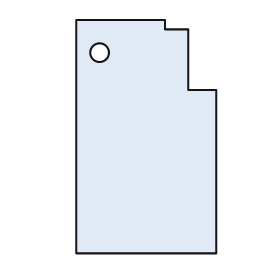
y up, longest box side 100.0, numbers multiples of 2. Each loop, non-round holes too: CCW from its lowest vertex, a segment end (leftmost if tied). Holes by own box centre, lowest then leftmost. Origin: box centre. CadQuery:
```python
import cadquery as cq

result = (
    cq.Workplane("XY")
    .moveTo(-30.0, -50.0)
    .lineTo(30.0, -50.0)
    .lineTo(30.0, 20.0)
    .lineTo(18.0, 20.0)
    .lineTo(18.0, 46.0)
    .lineTo(8.0, 46.0)
    .lineTo(8.0, 50.0)
    .lineTo(-30.0, 50.0)
    .close()
    .moveTo(-20.0, 36.0)
    .circle(4.0)
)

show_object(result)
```